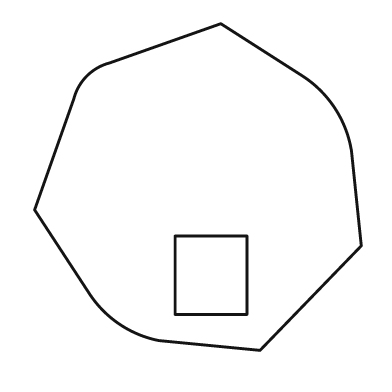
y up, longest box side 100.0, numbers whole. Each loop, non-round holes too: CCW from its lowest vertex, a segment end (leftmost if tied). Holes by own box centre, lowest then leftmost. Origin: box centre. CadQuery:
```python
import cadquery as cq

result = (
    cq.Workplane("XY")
    .moveTo(19.0, -50.0)
    .lineTo(50.0, -18.0)
    .lineTo(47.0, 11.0)
    .threePointArc((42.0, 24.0), (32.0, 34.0))
    .lineTo(7.0, 50.0)
    .lineTo(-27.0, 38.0)
    .threePointArc((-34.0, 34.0), (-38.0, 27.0))
    .lineTo(-50.0, -7.0)
    .lineTo(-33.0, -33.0)
    .threePointArc((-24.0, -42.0), (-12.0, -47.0))
    .close()
    .moveTo(-7.0, -39.0)
    .lineTo(15.0, -39.0)
    .lineTo(15.0, -15.0)
    .lineTo(-7.0, -15.0)
    .close()
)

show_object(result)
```